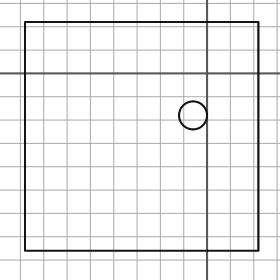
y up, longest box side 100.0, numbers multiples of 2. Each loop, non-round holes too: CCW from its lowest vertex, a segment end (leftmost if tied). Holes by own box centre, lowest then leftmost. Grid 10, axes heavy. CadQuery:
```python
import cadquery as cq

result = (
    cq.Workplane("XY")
    .moveTo(-78.0, -76.0)
    .lineTo(22.0, -76.0)
    .lineTo(22.0, 22.0)
    .lineTo(-78.0, 22.0)
    .close()
    .moveTo(-6.0, -18.0)
    .circle(6.0)
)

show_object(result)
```